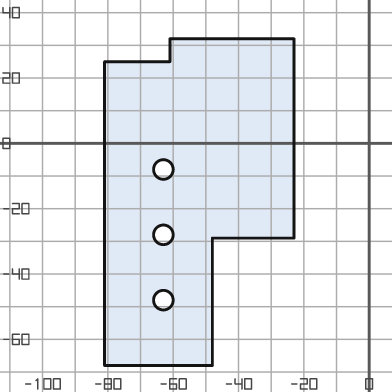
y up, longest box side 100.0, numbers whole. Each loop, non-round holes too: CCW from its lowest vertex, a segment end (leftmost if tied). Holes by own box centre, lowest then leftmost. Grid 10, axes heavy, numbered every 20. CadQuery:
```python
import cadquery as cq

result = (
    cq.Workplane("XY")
    .moveTo(-81.0, -68.0)
    .lineTo(-48.0, -68.0)
    .lineTo(-48.0, -29.0)
    .lineTo(-23.0, -29.0)
    .lineTo(-23.0, 32.0)
    .lineTo(-61.0, 32.0)
    .lineTo(-61.0, 25.0)
    .lineTo(-81.0, 25.0)
    .close()
    .moveTo(-63.0, -48.0)
    .circle(3.0)
    .moveTo(-63.0, -28.0)
    .circle(3.0)
    .moveTo(-63.0, -8.0)
    .circle(3.0)
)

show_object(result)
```